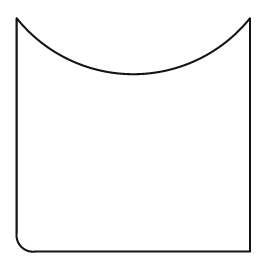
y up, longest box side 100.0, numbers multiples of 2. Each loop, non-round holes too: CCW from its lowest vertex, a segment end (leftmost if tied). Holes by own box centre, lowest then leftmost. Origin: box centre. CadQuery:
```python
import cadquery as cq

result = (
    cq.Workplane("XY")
    .moveTo(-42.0, -50.0)
    .lineTo(50.0, -50.0)
    .lineTo(50.0, 50.0)
    .threePointArc((0.0, 26.0), (-50.0, 50.0))
    .lineTo(-50.0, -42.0)
    .threePointArc((-48.0, -48.0), (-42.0, -50.0))
    .close()
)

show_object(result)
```